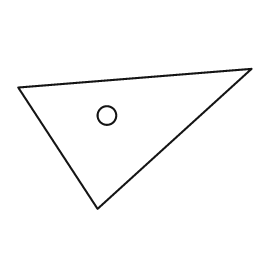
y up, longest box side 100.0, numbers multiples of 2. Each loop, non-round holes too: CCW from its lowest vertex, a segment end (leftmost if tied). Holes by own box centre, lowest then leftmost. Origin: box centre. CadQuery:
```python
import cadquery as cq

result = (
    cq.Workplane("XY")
    .moveTo(-16.0, -30.0)
    .lineTo(50.0, 30.0)
    .lineTo(-50.0, 22.0)
    .close()
    .moveTo(-12.0, 10.0)
    .circle(4.0)
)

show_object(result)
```